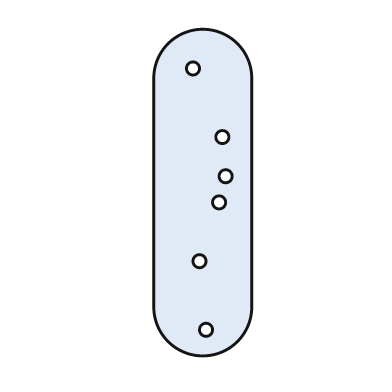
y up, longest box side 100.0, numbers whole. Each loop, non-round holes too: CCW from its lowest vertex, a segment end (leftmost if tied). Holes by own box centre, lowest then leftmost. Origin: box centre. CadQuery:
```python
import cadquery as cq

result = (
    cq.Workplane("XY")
    .moveTo(-15.0, -35.0)
    .threePointArc((0.0, -50.0), (15.0, -35.0))
    .lineTo(15.0, 35.0)
    .threePointArc((0.0, 50.0), (-15.0, 35.0))
    .close()
    .moveTo(1.0, -42.0)
    .circle(2.0)
    .moveTo(-1.0, -21.0)
    .circle(2.0)
    .moveTo(5.0, -3.0)
    .circle(2.0)
    .moveTo(7.0, 5.0)
    .circle(2.0)
    .moveTo(6.0, 17.0)
    .circle(2.0)
    .moveTo(-3.0, 38.0)
    .circle(2.0)
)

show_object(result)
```